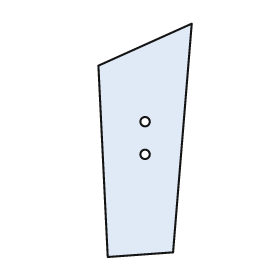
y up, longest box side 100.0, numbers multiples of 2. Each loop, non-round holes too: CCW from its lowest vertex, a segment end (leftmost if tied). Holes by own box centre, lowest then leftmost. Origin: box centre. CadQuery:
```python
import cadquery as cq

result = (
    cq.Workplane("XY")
    .moveTo(-16.0, -50.0)
    .lineTo(12.0, -48.0)
    .lineTo(20.0, 50.0)
    .lineTo(-20.0, 32.0)
    .close()
    .moveTo(0.0, -6.0)
    .circle(2.0)
    .moveTo(0.0, 8.0)
    .circle(2.0)
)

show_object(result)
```